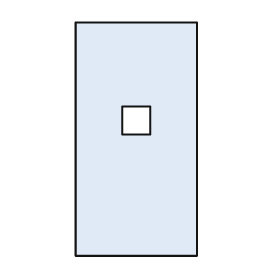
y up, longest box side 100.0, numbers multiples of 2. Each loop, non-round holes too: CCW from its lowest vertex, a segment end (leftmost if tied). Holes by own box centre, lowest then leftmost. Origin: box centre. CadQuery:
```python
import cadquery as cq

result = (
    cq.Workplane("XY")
    .moveTo(-26.0, -50.0)
    .lineTo(26.0, -50.0)
    .lineTo(26.0, 50.0)
    .lineTo(-26.0, 50.0)
    .close()
    .moveTo(-6.0, 2.0)
    .lineTo(6.0, 2.0)
    .lineTo(6.0, 14.0)
    .lineTo(-6.0, 14.0)
    .close()
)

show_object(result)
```